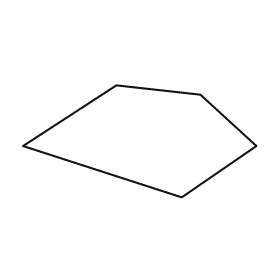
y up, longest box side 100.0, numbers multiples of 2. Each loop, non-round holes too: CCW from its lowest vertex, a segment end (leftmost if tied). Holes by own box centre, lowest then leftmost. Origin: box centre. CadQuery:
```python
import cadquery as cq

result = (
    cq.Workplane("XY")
    .moveTo(18.0, -24.0)
    .lineTo(50.0, -2.0)
    .lineTo(26.0, 20.0)
    .lineTo(-10.0, 24.0)
    .lineTo(-50.0, -2.0)
    .close()
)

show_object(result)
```